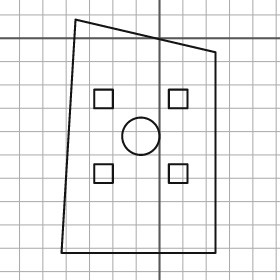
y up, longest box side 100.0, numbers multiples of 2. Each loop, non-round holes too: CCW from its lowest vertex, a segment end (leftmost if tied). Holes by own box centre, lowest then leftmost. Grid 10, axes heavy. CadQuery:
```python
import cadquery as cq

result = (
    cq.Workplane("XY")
    .moveTo(-42.0, -92.0)
    .lineTo(24.0, -92.0)
    .lineTo(24.0, -6.0)
    .lineTo(-36.0, 8.0)
    .close()
    .moveTo(-28.0, -62.0)
    .lineTo(-20.0, -62.0)
    .lineTo(-20.0, -54.0)
    .lineTo(-28.0, -54.0)
    .close()
    .moveTo(4.0, -62.0)
    .lineTo(12.0, -62.0)
    .lineTo(12.0, -54.0)
    .lineTo(4.0, -54.0)
    .close()
    .moveTo(-8.0, -42.0)
    .circle(8.0)
    .moveTo(-28.0, -30.0)
    .lineTo(-20.0, -30.0)
    .lineTo(-20.0, -22.0)
    .lineTo(-28.0, -22.0)
    .close()
    .moveTo(4.0, -30.0)
    .lineTo(12.0, -30.0)
    .lineTo(12.0, -22.0)
    .lineTo(4.0, -22.0)
    .close()
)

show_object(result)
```